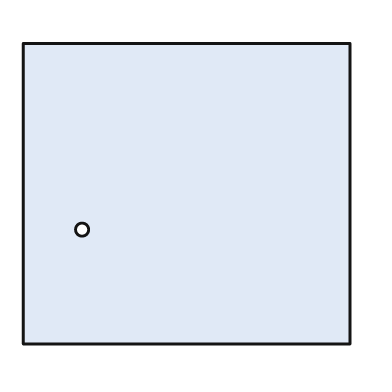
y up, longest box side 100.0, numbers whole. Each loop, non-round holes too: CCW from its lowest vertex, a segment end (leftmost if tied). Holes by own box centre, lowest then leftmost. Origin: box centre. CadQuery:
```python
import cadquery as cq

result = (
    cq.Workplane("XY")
    .moveTo(-50.0, -46.0)
    .lineTo(50.0, -46.0)
    .lineTo(50.0, 46.0)
    .lineTo(-50.0, 46.0)
    .close()
    .moveTo(-32.0, -11.0)
    .circle(2.0)
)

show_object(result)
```